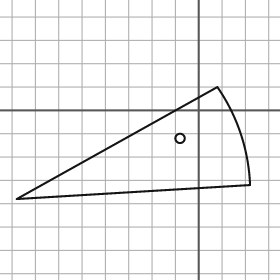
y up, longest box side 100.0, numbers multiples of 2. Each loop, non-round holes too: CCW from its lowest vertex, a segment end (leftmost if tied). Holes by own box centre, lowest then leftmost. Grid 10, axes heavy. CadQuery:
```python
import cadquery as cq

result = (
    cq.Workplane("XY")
    .moveTo(-78.0, -38.0)
    .lineTo(22.0, -32.0)
    .threePointArc((18.0, -10.0), (8.0, 10.0))
    .close()
    .moveTo(-8.0, -12.0)
    .circle(2.0)
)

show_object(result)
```